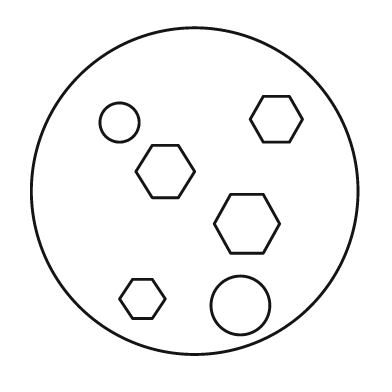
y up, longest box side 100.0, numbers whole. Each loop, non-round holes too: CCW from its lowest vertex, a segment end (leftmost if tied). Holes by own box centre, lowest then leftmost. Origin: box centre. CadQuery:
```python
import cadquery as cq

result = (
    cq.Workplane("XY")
    .moveTo(0.0, 0.0)
    .circle(50.0)
    .moveTo(14.0, -35.0)
    .circle(9.0)
    .moveTo(-19.0, -39.0)
    .lineTo(-13.0, -39.0)
    .lineTo(-9.0, -33.0)
    .lineTo(-13.0, -27.0)
    .lineTo(-19.0, -27.0)
    .lineTo(-23.0, -33.0)
    .close()
    .moveTo(11.0, -19.0)
    .lineTo(21.0, -19.0)
    .lineTo(26.0, -10.0)
    .lineTo(21.0, -1.0)
    .lineTo(11.0, -1.0)
    .lineTo(6.0, -10.0)
    .close()
    .moveTo(-13.0, -2.0)
    .lineTo(-5.0, -2.0)
    .lineTo(0.0, 6.0)
    .lineTo(-5.0, 14.0)
    .lineTo(-13.0, 14.0)
    .lineTo(-18.0, 6.0)
    .close()
    .moveTo(-23.0, 21.0)
    .circle(6.0)
    .moveTo(21.0, 15.0)
    .lineTo(29.0, 15.0)
    .lineTo(33.0, 22.0)
    .lineTo(29.0, 29.0)
    .lineTo(21.0, 29.0)
    .lineTo(17.0, 22.0)
    .close()
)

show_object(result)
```